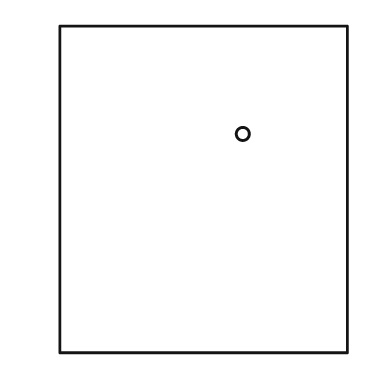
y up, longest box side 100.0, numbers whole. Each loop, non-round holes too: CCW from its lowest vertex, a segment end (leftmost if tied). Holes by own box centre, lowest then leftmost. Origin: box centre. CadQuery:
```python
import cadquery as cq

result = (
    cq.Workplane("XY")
    .moveTo(-44.0, -50.0)
    .lineTo(44.0, -50.0)
    .lineTo(44.0, 50.0)
    .lineTo(-44.0, 50.0)
    .close()
    .moveTo(12.0, 17.0)
    .circle(2.0)
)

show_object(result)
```